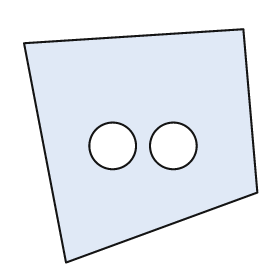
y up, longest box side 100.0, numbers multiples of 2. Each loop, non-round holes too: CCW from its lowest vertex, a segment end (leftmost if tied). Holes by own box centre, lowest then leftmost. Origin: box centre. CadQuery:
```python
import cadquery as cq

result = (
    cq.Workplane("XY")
    .moveTo(-32.0, -50.0)
    .lineTo(50.0, -20.0)
    .lineTo(44.0, 50.0)
    .lineTo(-50.0, 44.0)
    .close()
    .moveTo(-12.0, 0.0)
    .circle(10.0)
    .moveTo(14.0, 0.0)
    .circle(10.0)
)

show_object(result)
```